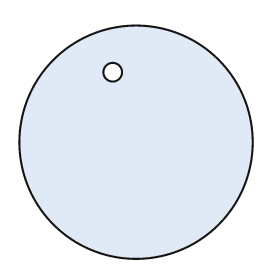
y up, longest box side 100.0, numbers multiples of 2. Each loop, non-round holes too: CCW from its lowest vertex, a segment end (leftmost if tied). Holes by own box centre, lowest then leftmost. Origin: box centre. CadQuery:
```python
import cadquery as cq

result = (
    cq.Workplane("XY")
    .moveTo(0.0, 0.0)
    .circle(50.0)
    .moveTo(-10.0, 30.0)
    .circle(4.0)
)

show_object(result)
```